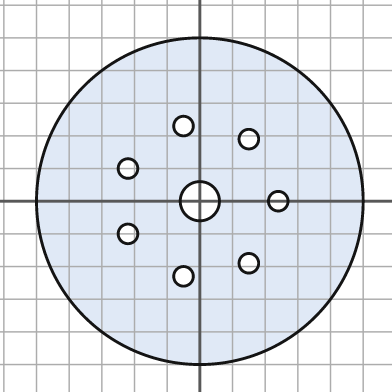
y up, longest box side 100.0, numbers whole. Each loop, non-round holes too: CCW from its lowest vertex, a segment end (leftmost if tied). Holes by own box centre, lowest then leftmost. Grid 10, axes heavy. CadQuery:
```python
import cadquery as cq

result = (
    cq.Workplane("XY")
    .moveTo(0.0, 0.0)
    .circle(50.0)
    .moveTo(-5.0, -23.0)
    .circle(3.0)
    .moveTo(15.0, -19.0)
    .circle(3.0)
    .moveTo(-22.0, -10.0)
    .circle(3.0)
    .moveTo(0.0, 0.0)
    .circle(6.0)
    .moveTo(24.0, 0.0)
    .circle(3.0)
    .moveTo(-22.0, 10.0)
    .circle(3.0)
    .moveTo(15.0, 19.0)
    .circle(3.0)
    .moveTo(-5.0, 23.0)
    .circle(3.0)
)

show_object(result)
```